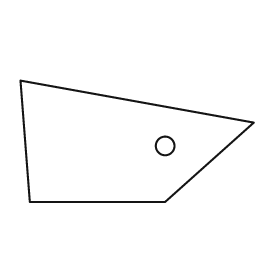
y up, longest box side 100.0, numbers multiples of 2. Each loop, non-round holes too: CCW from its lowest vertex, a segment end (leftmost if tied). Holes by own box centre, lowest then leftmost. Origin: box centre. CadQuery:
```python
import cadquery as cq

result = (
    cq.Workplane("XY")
    .moveTo(-46.0, -26.0)
    .lineTo(12.0, -26.0)
    .lineTo(50.0, 8.0)
    .lineTo(-50.0, 26.0)
    .close()
    .moveTo(12.0, -2.0)
    .circle(4.0)
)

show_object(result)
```